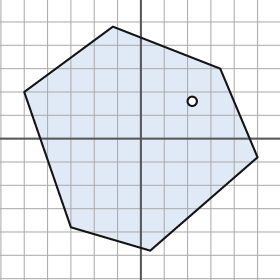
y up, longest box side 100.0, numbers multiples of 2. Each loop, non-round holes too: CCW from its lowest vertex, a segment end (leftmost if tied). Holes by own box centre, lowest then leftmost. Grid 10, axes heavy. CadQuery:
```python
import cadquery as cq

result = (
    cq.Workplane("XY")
    .moveTo(4.0, -48.0)
    .lineTo(50.0, -8.0)
    .lineTo(34.0, 30.0)
    .lineTo(-12.0, 48.0)
    .lineTo(-50.0, 20.0)
    .lineTo(-30.0, -38.0)
    .close()
    .moveTo(22.0, 16.0)
    .circle(2.0)
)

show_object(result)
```